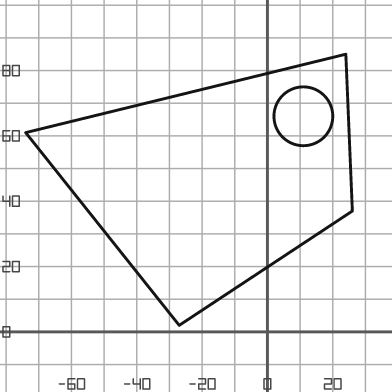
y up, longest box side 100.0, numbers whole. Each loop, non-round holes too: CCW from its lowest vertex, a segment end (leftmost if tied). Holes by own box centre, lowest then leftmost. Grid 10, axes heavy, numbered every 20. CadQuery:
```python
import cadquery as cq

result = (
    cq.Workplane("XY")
    .moveTo(-27.0, 2.0)
    .lineTo(26.0, 37.0)
    .lineTo(24.0, 85.0)
    .lineTo(-74.0, 61.0)
    .close()
    .moveTo(11.0, 66.0)
    .circle(9.0)
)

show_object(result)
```